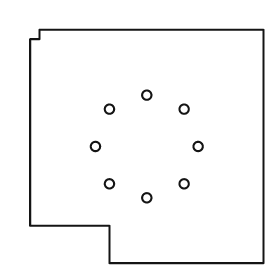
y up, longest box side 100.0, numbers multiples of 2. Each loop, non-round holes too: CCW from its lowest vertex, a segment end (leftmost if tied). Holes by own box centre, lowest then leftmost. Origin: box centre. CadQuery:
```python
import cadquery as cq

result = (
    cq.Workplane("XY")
    .moveTo(-16.0, -50.0)
    .lineTo(50.0, -50.0)
    .lineTo(50.0, 50.0)
    .lineTo(-46.0, 50.0)
    .lineTo(-46.0, 46.0)
    .lineTo(-50.0, 46.0)
    .lineTo(-50.0, -34.0)
    .lineTo(-16.0, -34.0)
    .close()
    .moveTo(0.0, -22.0)
    .circle(2.0)
    .moveTo(-16.0, -16.0)
    .circle(2.0)
    .moveTo(16.0, -16.0)
    .circle(2.0)
    .moveTo(-22.0, 0.0)
    .circle(2.0)
    .moveTo(22.0, 0.0)
    .circle(2.0)
    .moveTo(-16.0, 16.0)
    .circle(2.0)
    .moveTo(16.0, 16.0)
    .circle(2.0)
    .moveTo(0.0, 22.0)
    .circle(2.0)
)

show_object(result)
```